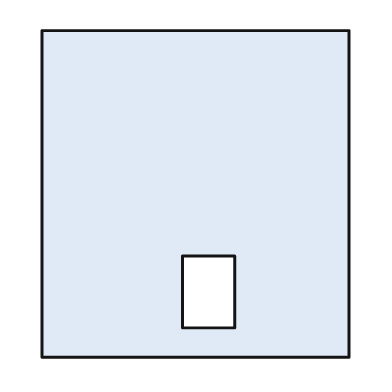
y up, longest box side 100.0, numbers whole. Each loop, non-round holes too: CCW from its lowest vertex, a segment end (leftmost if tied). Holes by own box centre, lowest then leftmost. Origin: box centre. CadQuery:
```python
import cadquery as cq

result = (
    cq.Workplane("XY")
    .moveTo(-47.0, -50.0)
    .lineTo(47.0, -50.0)
    .lineTo(47.0, 50.0)
    .lineTo(-47.0, 50.0)
    .close()
    .moveTo(-4.0, -41.0)
    .lineTo(12.0, -41.0)
    .lineTo(12.0, -19.0)
    .lineTo(-4.0, -19.0)
    .close()
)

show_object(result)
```